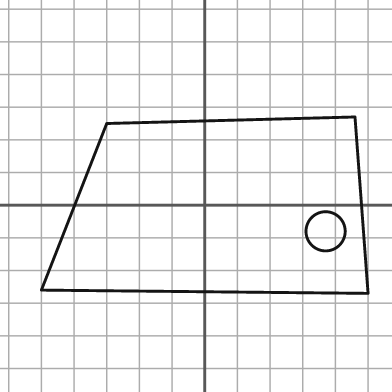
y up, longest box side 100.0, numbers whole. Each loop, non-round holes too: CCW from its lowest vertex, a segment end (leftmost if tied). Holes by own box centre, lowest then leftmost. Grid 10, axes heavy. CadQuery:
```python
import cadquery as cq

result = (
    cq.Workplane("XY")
    .moveTo(50.0, -27.0)
    .lineTo(46.0, 27.0)
    .lineTo(-30.0, 25.0)
    .lineTo(-50.0, -26.0)
    .close()
    .moveTo(37.0, -8.0)
    .circle(6.0)
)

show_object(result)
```